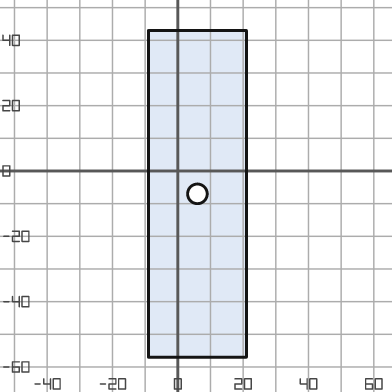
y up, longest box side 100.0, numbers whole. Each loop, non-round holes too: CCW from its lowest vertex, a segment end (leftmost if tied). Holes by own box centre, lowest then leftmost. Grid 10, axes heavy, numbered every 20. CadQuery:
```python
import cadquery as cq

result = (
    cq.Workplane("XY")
    .moveTo(-9.0, -57.0)
    .lineTo(21.0, -57.0)
    .lineTo(21.0, 43.0)
    .lineTo(-9.0, 43.0)
    .close()
    .moveTo(6.0, -7.0)
    .circle(3.0)
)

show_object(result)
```